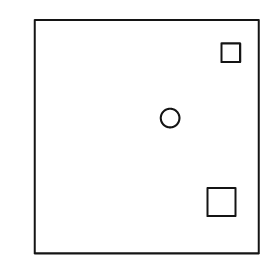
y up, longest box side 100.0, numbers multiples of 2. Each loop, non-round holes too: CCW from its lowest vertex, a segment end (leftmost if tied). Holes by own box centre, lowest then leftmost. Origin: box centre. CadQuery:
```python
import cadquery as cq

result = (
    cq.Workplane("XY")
    .moveTo(-48.0, -50.0)
    .lineTo(48.0, -50.0)
    .lineTo(48.0, 50.0)
    .lineTo(-48.0, 50.0)
    .close()
    .moveTo(26.0, -34.0)
    .lineTo(38.0, -34.0)
    .lineTo(38.0, -22.0)
    .lineTo(26.0, -22.0)
    .close()
    .moveTo(10.0, 8.0)
    .circle(4.0)
    .moveTo(32.0, 32.0)
    .lineTo(40.0, 32.0)
    .lineTo(40.0, 40.0)
    .lineTo(32.0, 40.0)
    .close()
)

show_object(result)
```